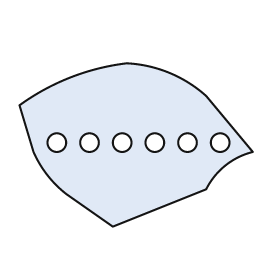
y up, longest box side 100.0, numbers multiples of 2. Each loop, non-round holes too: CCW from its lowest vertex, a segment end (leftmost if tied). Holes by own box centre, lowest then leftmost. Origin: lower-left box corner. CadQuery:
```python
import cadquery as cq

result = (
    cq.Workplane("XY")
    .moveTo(40.0, 0.0)
    .lineTo(80.0, 16.0)
    .threePointArc((88.0, 26.0), (100.0, 32.0))
    .lineTo(80.0, 56.0)
    .threePointArc((64.0, 66.0), (46.0, 70.0))
    .threePointArc((22.0, 64.0), (0.0, 52.0))
    .lineTo(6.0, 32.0)
    .threePointArc((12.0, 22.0), (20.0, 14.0))
    .close()
    .moveTo(16.0, 36.0)
    .circle(4.0)
    .moveTo(30.0, 36.0)
    .circle(4.0)
    .moveTo(44.0, 36.0)
    .circle(4.0)
    .moveTo(58.0, 36.0)
    .circle(4.0)
    .moveTo(72.0, 36.0)
    .circle(4.0)
    .moveTo(86.0, 36.0)
    .circle(4.0)
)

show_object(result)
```